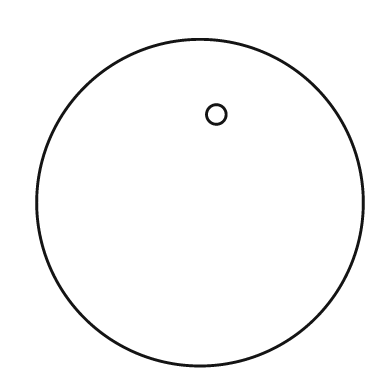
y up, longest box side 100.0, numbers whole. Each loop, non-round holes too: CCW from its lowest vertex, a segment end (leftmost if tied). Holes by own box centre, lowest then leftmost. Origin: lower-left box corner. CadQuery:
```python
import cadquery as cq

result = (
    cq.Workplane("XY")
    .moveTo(50.0, 50.0)
    .circle(50.0)
    .moveTo(55.0, 77.0)
    .circle(3.0)
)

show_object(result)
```